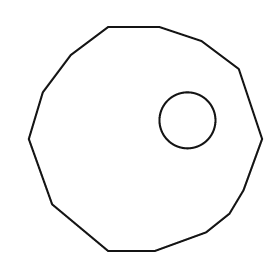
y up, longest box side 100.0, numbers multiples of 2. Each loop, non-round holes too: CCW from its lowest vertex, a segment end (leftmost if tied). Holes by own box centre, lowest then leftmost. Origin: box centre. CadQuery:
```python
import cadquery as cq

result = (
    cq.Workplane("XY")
    .moveTo(-16.0, -48.0)
    .lineTo(4.0, -48.0)
    .lineTo(26.0, -40.0)
    .lineTo(36.0, -32.0)
    .lineTo(42.0, -22.0)
    .lineTo(50.0, 0.0)
    .lineTo(40.0, 30.0)
    .lineTo(24.0, 42.0)
    .lineTo(6.0, 48.0)
    .lineTo(-16.0, 48.0)
    .lineTo(-32.0, 36.0)
    .lineTo(-44.0, 20.0)
    .lineTo(-50.0, 0.0)
    .lineTo(-40.0, -28.0)
    .close()
    .moveTo(18.0, 8.0)
    .circle(12.0)
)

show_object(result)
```